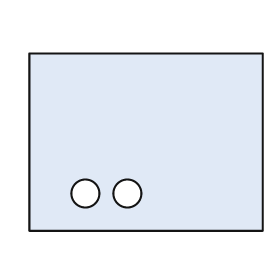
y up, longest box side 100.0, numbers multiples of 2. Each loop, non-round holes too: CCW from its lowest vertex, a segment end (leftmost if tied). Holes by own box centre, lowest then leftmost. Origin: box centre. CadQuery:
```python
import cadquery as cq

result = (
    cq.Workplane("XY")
    .moveTo(-50.0, -38.0)
    .lineTo(50.0, -38.0)
    .lineTo(50.0, 38.0)
    .lineTo(-50.0, 38.0)
    .close()
    .moveTo(-26.0, -22.0)
    .circle(6.0)
    .moveTo(-8.0, -22.0)
    .circle(6.0)
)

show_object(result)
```